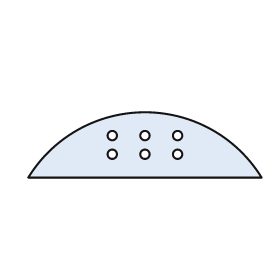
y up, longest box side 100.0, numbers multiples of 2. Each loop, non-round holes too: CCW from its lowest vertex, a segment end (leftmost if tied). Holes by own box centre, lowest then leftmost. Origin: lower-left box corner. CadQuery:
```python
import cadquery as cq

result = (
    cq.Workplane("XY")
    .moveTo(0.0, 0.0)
    .lineTo(100.0, 0.0)
    .threePointArc((50.0, 28.0), (0.0, 0.0))
    .close()
    .moveTo(36.0, 10.0)
    .circle(2.0)
    .moveTo(50.0, 10.0)
    .circle(2.0)
    .moveTo(64.0, 10.0)
    .circle(2.0)
    .moveTo(36.0, 18.0)
    .circle(2.0)
    .moveTo(50.0, 18.0)
    .circle(2.0)
    .moveTo(64.0, 18.0)
    .circle(2.0)
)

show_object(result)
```